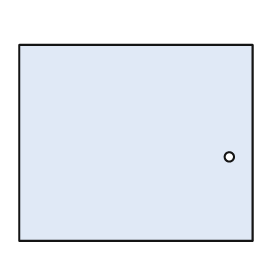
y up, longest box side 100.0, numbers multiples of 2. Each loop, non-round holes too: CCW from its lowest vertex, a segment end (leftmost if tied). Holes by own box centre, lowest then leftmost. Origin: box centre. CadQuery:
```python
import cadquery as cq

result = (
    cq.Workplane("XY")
    .moveTo(-50.0, -42.0)
    .lineTo(50.0, -42.0)
    .lineTo(50.0, 42.0)
    .lineTo(-50.0, 42.0)
    .close()
    .moveTo(40.0, -6.0)
    .circle(2.0)
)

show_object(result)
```